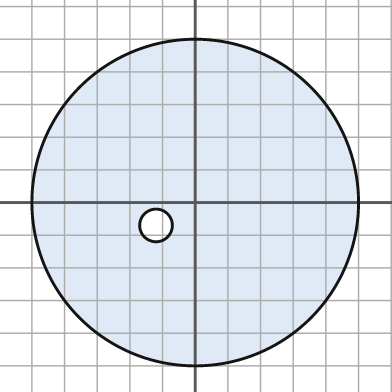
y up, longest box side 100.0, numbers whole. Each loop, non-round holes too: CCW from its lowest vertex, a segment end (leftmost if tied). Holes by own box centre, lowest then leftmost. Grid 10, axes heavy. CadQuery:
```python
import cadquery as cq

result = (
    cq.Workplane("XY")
    .moveTo(0.0, 0.0)
    .circle(50.0)
    .moveTo(-12.0, -7.0)
    .circle(5.0)
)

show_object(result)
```